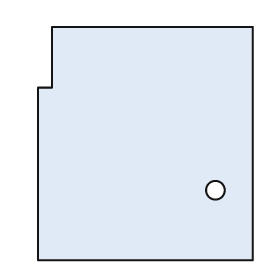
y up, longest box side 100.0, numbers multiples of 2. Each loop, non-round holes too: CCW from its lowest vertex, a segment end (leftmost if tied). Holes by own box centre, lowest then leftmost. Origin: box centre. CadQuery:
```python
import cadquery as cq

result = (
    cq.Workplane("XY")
    .moveTo(-46.0, -50.0)
    .lineTo(46.0, -50.0)
    .lineTo(46.0, 50.0)
    .lineTo(-40.0, 50.0)
    .lineTo(-40.0, 24.0)
    .lineTo(-46.0, 24.0)
    .close()
    .moveTo(30.0, -20.0)
    .circle(4.0)
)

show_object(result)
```